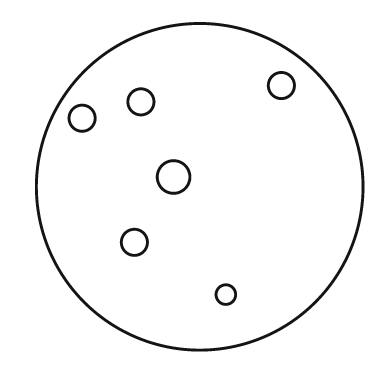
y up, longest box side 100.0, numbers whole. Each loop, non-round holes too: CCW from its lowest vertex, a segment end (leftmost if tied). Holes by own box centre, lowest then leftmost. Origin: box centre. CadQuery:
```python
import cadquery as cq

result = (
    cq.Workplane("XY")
    .moveTo(0.0, 0.0)
    .circle(50.0)
    .moveTo(8.0, -33.0)
    .circle(3.0)
    .moveTo(-20.0, -17.0)
    .circle(4.0)
    .moveTo(-8.0, 3.0)
    .circle(5.0)
    .moveTo(-36.0, 21.0)
    .circle(4.0)
    .moveTo(-18.0, 26.0)
    .circle(4.0)
    .moveTo(25.0, 31.0)
    .circle(4.0)
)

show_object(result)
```